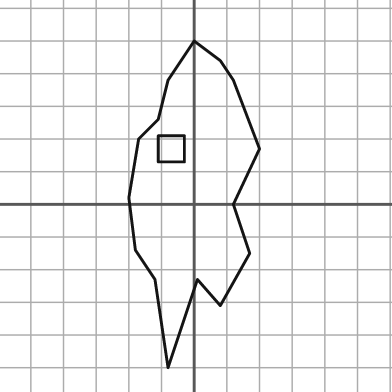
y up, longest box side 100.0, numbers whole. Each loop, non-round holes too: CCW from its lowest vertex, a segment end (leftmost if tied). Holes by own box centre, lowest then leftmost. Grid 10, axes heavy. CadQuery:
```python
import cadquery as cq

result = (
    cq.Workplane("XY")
    .moveTo(-8.0, -50.0)
    .lineTo(1.0, -23.0)
    .lineTo(8.0, -31.0)
    .lineTo(17.0, -15.0)
    .lineTo(12.0, 0.0)
    .lineTo(20.0, 17.0)
    .lineTo(12.0, 38.0)
    .lineTo(8.0, 44.0)
    .lineTo(0.0, 50.0)
    .lineTo(-8.0, 38.0)
    .lineTo(-11.0, 26.0)
    .lineTo(-17.0, 20.0)
    .lineTo(-20.0, 2.0)
    .lineTo(-18.0, -14.0)
    .lineTo(-12.0, -23.0)
    .close()
    .moveTo(-11.0, 13.0)
    .lineTo(-3.0, 13.0)
    .lineTo(-3.0, 21.0)
    .lineTo(-11.0, 21.0)
    .close()
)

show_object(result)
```